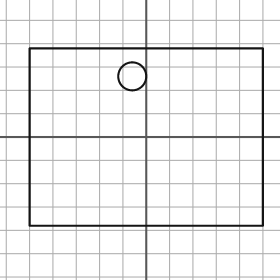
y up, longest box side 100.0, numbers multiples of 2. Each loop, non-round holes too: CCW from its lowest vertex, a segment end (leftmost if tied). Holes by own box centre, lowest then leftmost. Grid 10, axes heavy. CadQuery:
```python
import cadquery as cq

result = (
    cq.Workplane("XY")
    .moveTo(-50.0, -38.0)
    .lineTo(50.0, -38.0)
    .lineTo(50.0, 38.0)
    .lineTo(-50.0, 38.0)
    .close()
    .moveTo(-6.0, 26.0)
    .circle(6.0)
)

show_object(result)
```